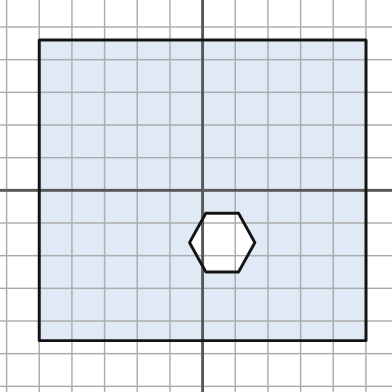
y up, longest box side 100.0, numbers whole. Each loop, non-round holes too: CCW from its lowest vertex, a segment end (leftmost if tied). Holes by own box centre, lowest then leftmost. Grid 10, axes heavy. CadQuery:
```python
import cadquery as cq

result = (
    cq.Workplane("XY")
    .moveTo(-50.0, -46.0)
    .lineTo(50.0, -46.0)
    .lineTo(50.0, 46.0)
    .lineTo(-50.0, 46.0)
    .close()
    .moveTo(1.0, -25.0)
    .lineTo(11.0, -25.0)
    .lineTo(16.0, -16.0)
    .lineTo(11.0, -7.0)
    .lineTo(1.0, -7.0)
    .lineTo(-4.0, -16.0)
    .close()
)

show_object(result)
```